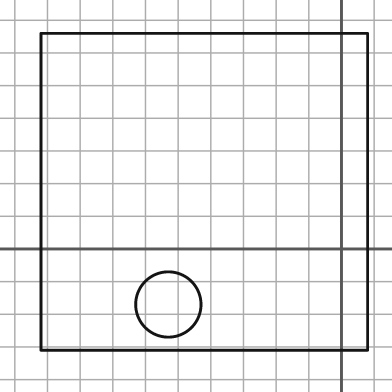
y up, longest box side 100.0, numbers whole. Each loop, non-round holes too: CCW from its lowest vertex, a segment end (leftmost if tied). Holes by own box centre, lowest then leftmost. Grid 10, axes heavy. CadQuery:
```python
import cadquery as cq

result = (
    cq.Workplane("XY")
    .moveTo(-92.0, -31.0)
    .lineTo(8.0, -31.0)
    .lineTo(8.0, 66.0)
    .lineTo(-92.0, 66.0)
    .close()
    .moveTo(-53.0, -17.0)
    .circle(10.0)
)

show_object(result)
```